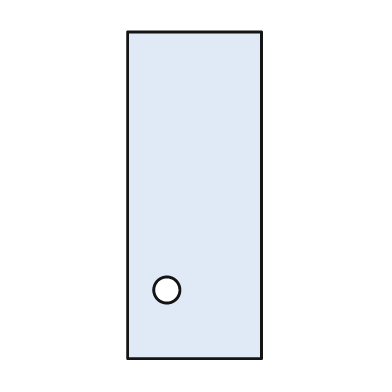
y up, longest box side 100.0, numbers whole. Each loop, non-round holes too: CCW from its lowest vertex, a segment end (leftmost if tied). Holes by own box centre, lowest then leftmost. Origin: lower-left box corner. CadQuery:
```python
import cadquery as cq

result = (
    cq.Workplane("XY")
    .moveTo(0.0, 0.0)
    .lineTo(41.0, 0.0)
    .lineTo(41.0, 100.0)
    .lineTo(0.0, 100.0)
    .close()
    .moveTo(12.0, 21.0)
    .circle(4.0)
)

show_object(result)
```